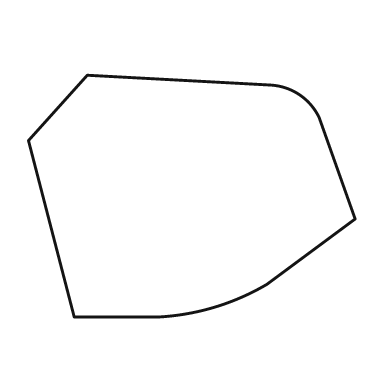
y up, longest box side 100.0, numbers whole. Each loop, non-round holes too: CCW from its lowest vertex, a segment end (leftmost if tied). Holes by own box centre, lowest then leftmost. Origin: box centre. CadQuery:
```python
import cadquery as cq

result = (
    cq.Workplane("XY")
    .moveTo(-36.0, -37.0)
    .lineTo(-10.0, -37.0)
    .threePointArc((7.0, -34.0), (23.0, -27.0))
    .lineTo(50.0, -7.0)
    .lineTo(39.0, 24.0)
    .threePointArc((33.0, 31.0), (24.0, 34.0))
    .lineTo(-32.0, 37.0)
    .lineTo(-50.0, 17.0)
    .close()
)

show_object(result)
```